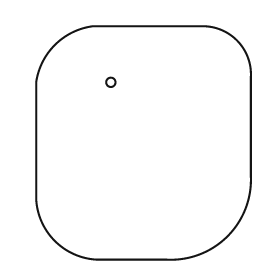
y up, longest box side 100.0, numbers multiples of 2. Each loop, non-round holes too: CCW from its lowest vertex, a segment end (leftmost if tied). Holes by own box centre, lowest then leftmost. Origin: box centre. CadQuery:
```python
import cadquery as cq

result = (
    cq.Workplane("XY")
    .moveTo(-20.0, -50.0)
    .lineTo(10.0, -50.0)
    .threePointArc((36.0, -40.0), (46.0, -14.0))
    .lineTo(46.0, 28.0)
    .threePointArc((40.0, 44.0), (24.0, 50.0))
    .lineTo(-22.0, 50.0)
    .threePointArc((-38.0, 42.0), (-46.0, 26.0))
    .lineTo(-46.0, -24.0)
    .threePointArc((-38.0, -42.0), (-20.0, -50.0))
    .close()
    .moveTo(-14.0, 26.0)
    .circle(2.0)
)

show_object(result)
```